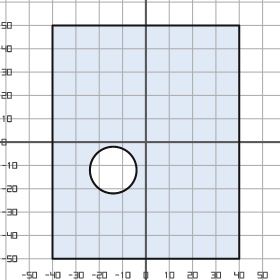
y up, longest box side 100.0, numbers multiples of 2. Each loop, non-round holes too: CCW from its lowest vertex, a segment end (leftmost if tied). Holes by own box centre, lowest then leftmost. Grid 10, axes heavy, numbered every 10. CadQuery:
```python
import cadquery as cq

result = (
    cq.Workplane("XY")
    .moveTo(-40.0, -50.0)
    .lineTo(40.0, -50.0)
    .lineTo(40.0, 50.0)
    .lineTo(-40.0, 50.0)
    .close()
    .moveTo(-14.0, -12.0)
    .circle(10.0)
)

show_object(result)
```